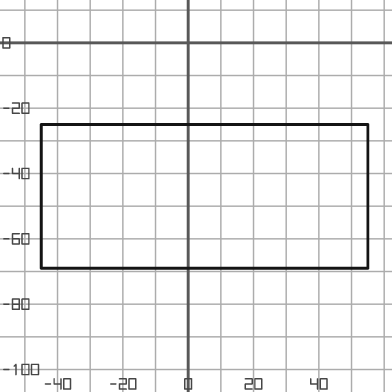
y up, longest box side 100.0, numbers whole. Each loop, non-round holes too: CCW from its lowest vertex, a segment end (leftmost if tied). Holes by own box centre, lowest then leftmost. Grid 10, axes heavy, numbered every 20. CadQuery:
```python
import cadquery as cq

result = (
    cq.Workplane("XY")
    .moveTo(-45.0, -69.0)
    .lineTo(55.0, -69.0)
    .lineTo(55.0, -25.0)
    .lineTo(-45.0, -25.0)
    .close()
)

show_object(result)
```